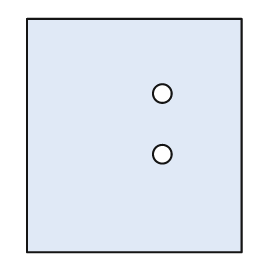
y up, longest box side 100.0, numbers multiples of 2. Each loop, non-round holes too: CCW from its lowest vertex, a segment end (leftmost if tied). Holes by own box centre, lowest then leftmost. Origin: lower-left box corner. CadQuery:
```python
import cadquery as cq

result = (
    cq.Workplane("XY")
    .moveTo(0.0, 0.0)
    .lineTo(92.0, 0.0)
    .lineTo(92.0, 100.0)
    .lineTo(0.0, 100.0)
    .close()
    .moveTo(58.0, 42.0)
    .circle(4.0)
    .moveTo(58.0, 68.0)
    .circle(4.0)
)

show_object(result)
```